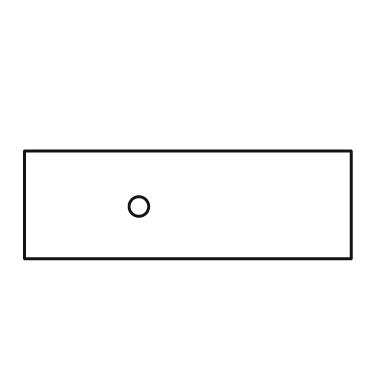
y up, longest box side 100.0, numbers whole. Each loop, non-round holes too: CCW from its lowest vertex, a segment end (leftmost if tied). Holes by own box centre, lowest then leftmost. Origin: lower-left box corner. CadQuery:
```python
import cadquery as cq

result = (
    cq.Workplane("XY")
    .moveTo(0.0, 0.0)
    .lineTo(100.0, 0.0)
    .lineTo(100.0, 33.0)
    .lineTo(0.0, 33.0)
    .close()
    .moveTo(35.0, 16.0)
    .circle(3.0)
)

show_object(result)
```